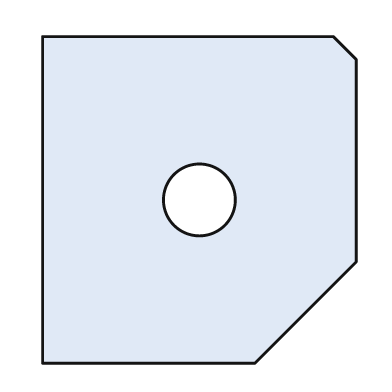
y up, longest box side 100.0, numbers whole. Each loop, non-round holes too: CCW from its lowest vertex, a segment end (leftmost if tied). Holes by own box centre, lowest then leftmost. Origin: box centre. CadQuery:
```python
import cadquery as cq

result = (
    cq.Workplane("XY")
    .moveTo(-48.0, -50.0)
    .lineTo(17.0, -50.0)
    .lineTo(48.0, -19.0)
    .lineTo(48.0, 43.0)
    .lineTo(41.0, 50.0)
    .lineTo(-48.0, 50.0)
    .close()
    .moveTo(0.0, 0.0)
    .circle(11.0)
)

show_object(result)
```